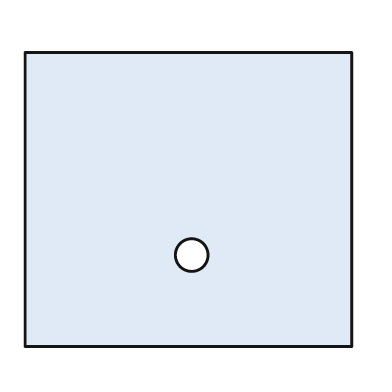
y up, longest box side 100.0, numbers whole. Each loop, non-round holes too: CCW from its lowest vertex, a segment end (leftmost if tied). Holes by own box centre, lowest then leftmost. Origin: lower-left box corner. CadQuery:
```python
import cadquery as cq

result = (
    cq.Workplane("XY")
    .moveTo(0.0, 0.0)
    .lineTo(100.0, 0.0)
    .lineTo(100.0, 90.0)
    .lineTo(0.0, 90.0)
    .close()
    .moveTo(51.0, 28.0)
    .circle(5.0)
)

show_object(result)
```